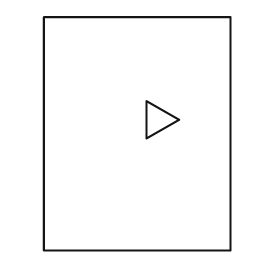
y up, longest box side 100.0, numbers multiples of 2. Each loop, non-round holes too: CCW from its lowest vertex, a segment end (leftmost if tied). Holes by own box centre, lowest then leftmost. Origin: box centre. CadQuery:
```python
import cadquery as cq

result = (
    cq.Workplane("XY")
    .moveTo(-40.0, -50.0)
    .lineTo(40.0, -50.0)
    .lineTo(40.0, 50.0)
    .lineTo(-40.0, 50.0)
    .close()
    .moveTo(4.0, -2.0)
    .lineTo(18.0, 6.0)
    .lineTo(4.0, 14.0)
    .close()
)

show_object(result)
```